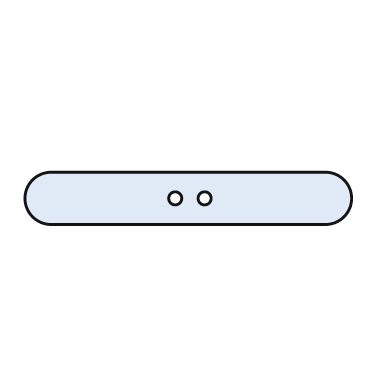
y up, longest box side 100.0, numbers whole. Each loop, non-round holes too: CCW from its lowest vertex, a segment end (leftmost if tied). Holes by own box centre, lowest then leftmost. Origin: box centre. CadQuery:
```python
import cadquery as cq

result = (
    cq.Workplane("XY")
    .moveTo(-42.0, -8.0)
    .lineTo(42.0, -8.0)
    .threePointArc((50.0, 0.0), (42.0, 8.0))
    .lineTo(-42.0, 8.0)
    .threePointArc((-50.0, 0.0), (-42.0, -8.0))
    .close()
    .moveTo(-4.0, 0.0)
    .circle(2.0)
    .moveTo(5.0, 0.0)
    .circle(2.0)
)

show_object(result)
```